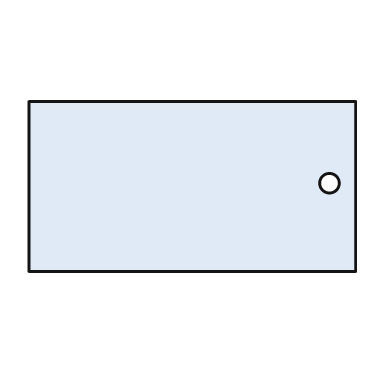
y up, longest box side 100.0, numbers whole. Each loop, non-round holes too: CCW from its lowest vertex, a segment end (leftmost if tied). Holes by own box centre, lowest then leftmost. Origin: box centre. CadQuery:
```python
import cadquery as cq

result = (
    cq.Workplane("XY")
    .moveTo(-50.0, -26.0)
    .lineTo(50.0, -26.0)
    .lineTo(50.0, 26.0)
    .lineTo(-50.0, 26.0)
    .close()
    .moveTo(42.0, 1.0)
    .circle(3.0)
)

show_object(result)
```